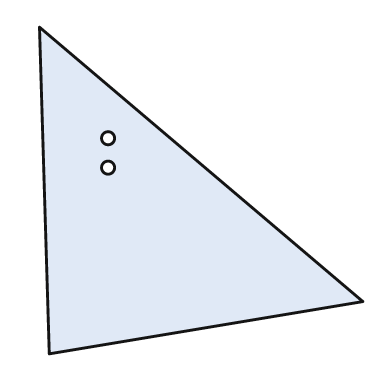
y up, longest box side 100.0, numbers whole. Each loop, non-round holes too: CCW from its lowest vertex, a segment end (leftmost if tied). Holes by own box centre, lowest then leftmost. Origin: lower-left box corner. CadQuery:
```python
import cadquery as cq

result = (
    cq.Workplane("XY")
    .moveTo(3.0, 0.0)
    .lineTo(99.0, 16.0)
    .lineTo(0.0, 100.0)
    .close()
    .moveTo(21.0, 57.0)
    .circle(2.0)
    .moveTo(21.0, 66.0)
    .circle(2.0)
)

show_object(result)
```